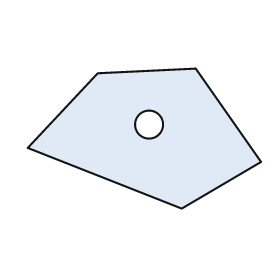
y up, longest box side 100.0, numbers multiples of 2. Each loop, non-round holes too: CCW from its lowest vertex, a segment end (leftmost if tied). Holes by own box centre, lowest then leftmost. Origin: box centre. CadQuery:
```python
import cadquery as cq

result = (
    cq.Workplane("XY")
    .moveTo(16.0, -30.0)
    .lineTo(50.0, -10.0)
    .lineTo(22.0, 30.0)
    .lineTo(-20.0, 28.0)
    .lineTo(-50.0, -4.0)
    .close()
    .moveTo(2.0, 6.0)
    .circle(6.0)
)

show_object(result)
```